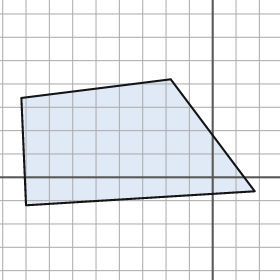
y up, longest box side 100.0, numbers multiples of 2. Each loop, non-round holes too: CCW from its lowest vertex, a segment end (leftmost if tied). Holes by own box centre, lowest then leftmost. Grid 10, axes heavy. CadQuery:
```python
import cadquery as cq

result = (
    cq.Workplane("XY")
    .moveTo(-80.0, -12.0)
    .lineTo(18.0, -6.0)
    .lineTo(-18.0, 42.0)
    .lineTo(-82.0, 34.0)
    .close()
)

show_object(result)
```